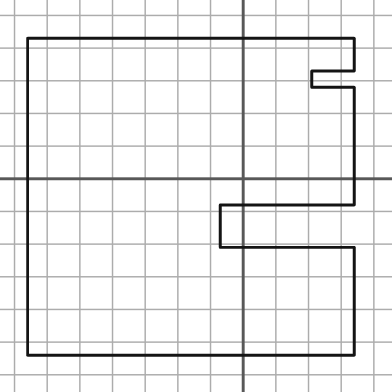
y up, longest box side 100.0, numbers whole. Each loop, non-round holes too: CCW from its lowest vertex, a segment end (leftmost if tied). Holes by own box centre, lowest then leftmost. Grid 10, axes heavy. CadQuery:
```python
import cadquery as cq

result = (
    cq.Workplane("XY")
    .moveTo(-66.0, -54.0)
    .lineTo(34.0, -54.0)
    .lineTo(34.0, -21.0)
    .lineTo(-7.0, -21.0)
    .lineTo(-7.0, -8.0)
    .lineTo(34.0, -8.0)
    .lineTo(34.0, 28.0)
    .lineTo(21.0, 28.0)
    .lineTo(21.0, 33.0)
    .lineTo(34.0, 33.0)
    .lineTo(34.0, 43.0)
    .lineTo(-66.0, 43.0)
    .close()
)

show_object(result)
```